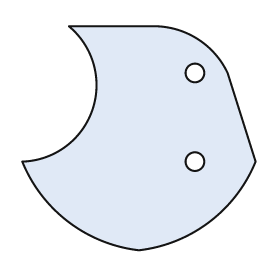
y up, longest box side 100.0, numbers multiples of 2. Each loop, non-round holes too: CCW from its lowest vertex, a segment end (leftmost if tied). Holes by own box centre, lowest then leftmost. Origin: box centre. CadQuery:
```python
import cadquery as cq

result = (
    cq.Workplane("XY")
    .moveTo(0.0, -48.0)
    .threePointArc((30.0, -36.0), (50.0, -10.0))
    .lineTo(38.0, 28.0)
    .threePointArc((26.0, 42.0), (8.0, 48.0))
    .lineTo(-30.0, 48.0)
    .threePointArc((-20.0, 12.0), (-50.0, -10.0))
    .threePointArc((-30.0, -36.0), (0.0, -48.0))
    .close()
    .moveTo(24.0, -10.0)
    .circle(4.0)
    .moveTo(24.0, 28.0)
    .circle(4.0)
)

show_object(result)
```